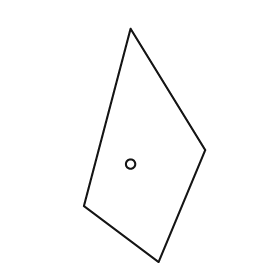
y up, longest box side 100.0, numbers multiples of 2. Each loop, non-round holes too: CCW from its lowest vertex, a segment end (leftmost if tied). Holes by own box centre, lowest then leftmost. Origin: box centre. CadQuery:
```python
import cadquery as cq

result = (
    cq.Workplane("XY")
    .moveTo(6.0, -50.0)
    .lineTo(26.0, -2.0)
    .lineTo(-6.0, 50.0)
    .lineTo(-26.0, -26.0)
    .close()
    .moveTo(-6.0, -8.0)
    .circle(2.0)
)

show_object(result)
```